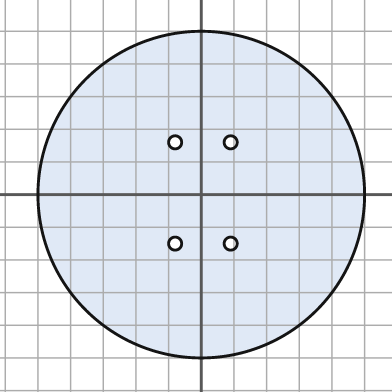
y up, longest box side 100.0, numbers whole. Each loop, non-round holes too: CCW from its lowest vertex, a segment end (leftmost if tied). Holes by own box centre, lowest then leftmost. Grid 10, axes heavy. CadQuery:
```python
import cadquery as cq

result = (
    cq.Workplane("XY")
    .moveTo(0.0, 0.0)
    .circle(50.0)
    .moveTo(-8.0, -15.0)
    .circle(2.0)
    .moveTo(9.0, -15.0)
    .circle(2.0)
    .moveTo(-8.0, 16.0)
    .circle(2.0)
    .moveTo(9.0, 16.0)
    .circle(2.0)
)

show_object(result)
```